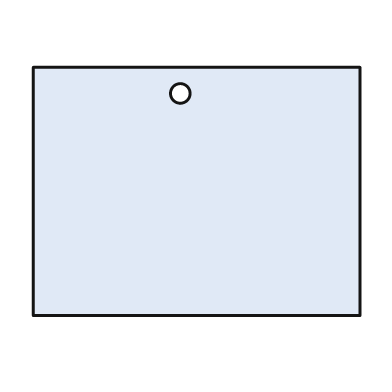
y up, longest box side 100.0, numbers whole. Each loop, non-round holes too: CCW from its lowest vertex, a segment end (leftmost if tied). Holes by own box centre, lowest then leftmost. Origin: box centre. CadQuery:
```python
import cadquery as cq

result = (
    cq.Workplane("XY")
    .moveTo(-50.0, -38.0)
    .lineTo(50.0, -38.0)
    .lineTo(50.0, 38.0)
    .lineTo(-50.0, 38.0)
    .close()
    .moveTo(-5.0, 30.0)
    .circle(3.0)
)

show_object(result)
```